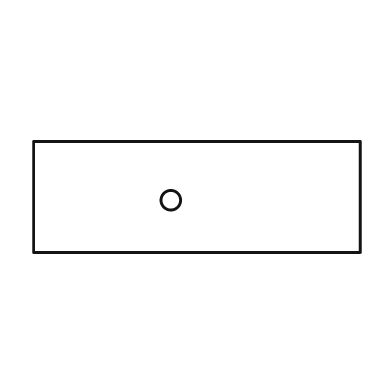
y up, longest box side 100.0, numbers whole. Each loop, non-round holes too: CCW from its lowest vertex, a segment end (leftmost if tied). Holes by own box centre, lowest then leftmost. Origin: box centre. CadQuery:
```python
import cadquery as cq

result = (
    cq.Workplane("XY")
    .moveTo(-50.0, -17.0)
    .lineTo(50.0, -17.0)
    .lineTo(50.0, 17.0)
    .lineTo(-50.0, 17.0)
    .close()
    .moveTo(-8.0, -1.0)
    .circle(3.0)
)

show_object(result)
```